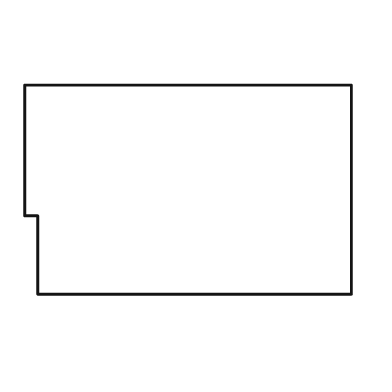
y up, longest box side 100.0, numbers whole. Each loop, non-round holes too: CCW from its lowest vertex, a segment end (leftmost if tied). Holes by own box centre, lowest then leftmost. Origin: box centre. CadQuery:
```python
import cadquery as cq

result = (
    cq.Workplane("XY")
    .moveTo(-46.0, -32.0)
    .lineTo(50.0, -32.0)
    .lineTo(50.0, 32.0)
    .lineTo(-50.0, 32.0)
    .lineTo(-50.0, -8.0)
    .lineTo(-46.0, -8.0)
    .close()
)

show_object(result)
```